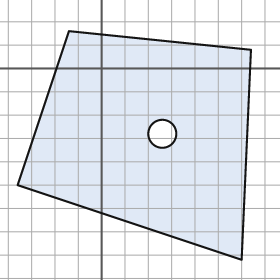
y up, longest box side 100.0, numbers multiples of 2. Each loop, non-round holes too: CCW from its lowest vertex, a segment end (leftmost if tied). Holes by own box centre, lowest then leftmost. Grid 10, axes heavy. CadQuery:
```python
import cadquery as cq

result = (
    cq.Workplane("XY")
    .moveTo(60.0, -82.0)
    .lineTo(64.0, 8.0)
    .lineTo(-14.0, 16.0)
    .lineTo(-36.0, -50.0)
    .close()
    .moveTo(26.0, -28.0)
    .circle(6.0)
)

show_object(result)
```